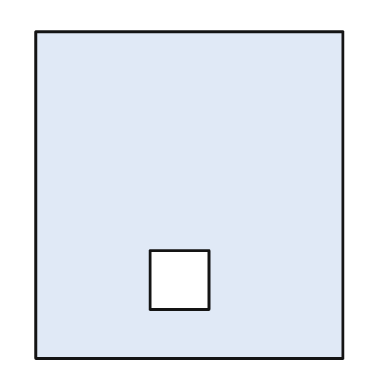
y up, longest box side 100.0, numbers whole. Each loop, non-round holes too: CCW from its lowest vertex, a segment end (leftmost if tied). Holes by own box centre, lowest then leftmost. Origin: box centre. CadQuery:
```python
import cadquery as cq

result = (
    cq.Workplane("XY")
    .moveTo(-47.0, -50.0)
    .lineTo(47.0, -50.0)
    .lineTo(47.0, 50.0)
    .lineTo(-47.0, 50.0)
    .close()
    .moveTo(-12.0, -35.0)
    .lineTo(6.0, -35.0)
    .lineTo(6.0, -17.0)
    .lineTo(-12.0, -17.0)
    .close()
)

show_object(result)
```